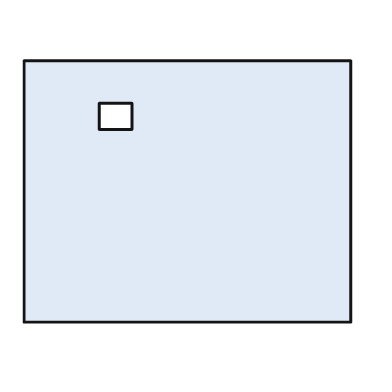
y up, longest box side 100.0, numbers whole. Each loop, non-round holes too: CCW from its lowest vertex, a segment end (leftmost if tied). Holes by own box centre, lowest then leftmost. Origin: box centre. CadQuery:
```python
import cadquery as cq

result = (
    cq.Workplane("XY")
    .moveTo(-50.0, -40.0)
    .lineTo(50.0, -40.0)
    .lineTo(50.0, 40.0)
    .lineTo(-50.0, 40.0)
    .close()
    .moveTo(-27.0, 19.0)
    .lineTo(-17.0, 19.0)
    .lineTo(-17.0, 27.0)
    .lineTo(-27.0, 27.0)
    .close()
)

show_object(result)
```